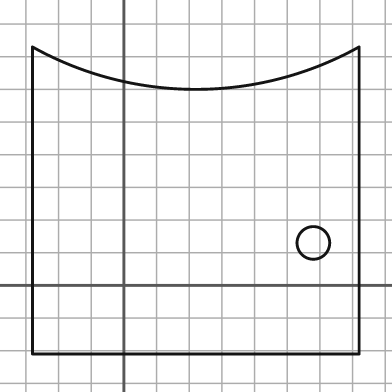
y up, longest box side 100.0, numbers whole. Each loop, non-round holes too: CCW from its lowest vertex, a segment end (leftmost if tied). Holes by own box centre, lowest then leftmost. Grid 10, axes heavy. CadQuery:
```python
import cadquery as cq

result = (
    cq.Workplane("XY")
    .moveTo(-28.0, -21.0)
    .lineTo(72.0, -21.0)
    .lineTo(72.0, 73.0)
    .threePointArc((22.0, 60.0), (-28.0, 73.0))
    .close()
    .moveTo(58.0, 13.0)
    .circle(5.0)
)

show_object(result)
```